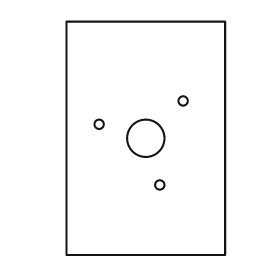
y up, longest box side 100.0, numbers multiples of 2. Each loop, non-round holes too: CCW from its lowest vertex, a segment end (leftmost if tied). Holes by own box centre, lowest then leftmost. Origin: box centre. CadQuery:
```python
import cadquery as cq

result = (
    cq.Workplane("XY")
    .moveTo(-34.0, -50.0)
    .lineTo(34.0, -50.0)
    .lineTo(34.0, 50.0)
    .lineTo(-34.0, 50.0)
    .close()
    .moveTo(6.0, -20.0)
    .circle(2.0)
    .moveTo(0.0, 0.0)
    .circle(8.0)
    .moveTo(-20.0, 6.0)
    .circle(2.0)
    .moveTo(16.0, 16.0)
    .circle(2.0)
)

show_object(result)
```